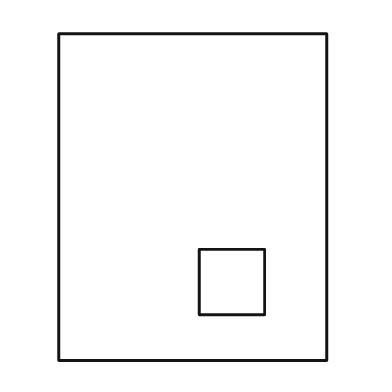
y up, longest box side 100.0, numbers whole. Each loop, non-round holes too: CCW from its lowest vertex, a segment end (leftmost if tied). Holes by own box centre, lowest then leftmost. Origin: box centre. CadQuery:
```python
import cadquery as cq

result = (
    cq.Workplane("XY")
    .moveTo(-41.0, -50.0)
    .lineTo(41.0, -50.0)
    .lineTo(41.0, 50.0)
    .lineTo(-41.0, 50.0)
    .close()
    .moveTo(2.0, -36.0)
    .lineTo(22.0, -36.0)
    .lineTo(22.0, -16.0)
    .lineTo(2.0, -16.0)
    .close()
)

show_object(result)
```